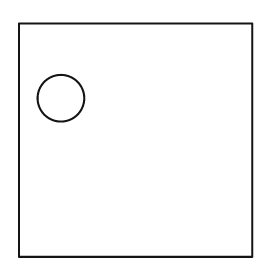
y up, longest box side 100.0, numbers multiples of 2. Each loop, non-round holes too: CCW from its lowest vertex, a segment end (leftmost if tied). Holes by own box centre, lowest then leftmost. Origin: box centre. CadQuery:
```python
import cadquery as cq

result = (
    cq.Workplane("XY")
    .moveTo(-50.0, -50.0)
    .lineTo(50.0, -50.0)
    .lineTo(50.0, 50.0)
    .lineTo(-50.0, 50.0)
    .close()
    .moveTo(-32.0, 18.0)
    .circle(10.0)
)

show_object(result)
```